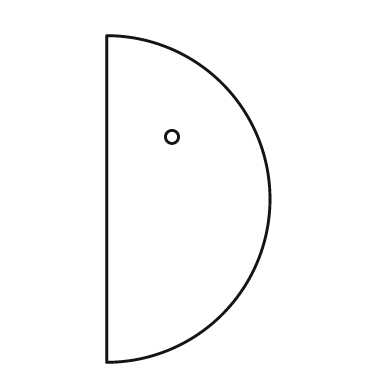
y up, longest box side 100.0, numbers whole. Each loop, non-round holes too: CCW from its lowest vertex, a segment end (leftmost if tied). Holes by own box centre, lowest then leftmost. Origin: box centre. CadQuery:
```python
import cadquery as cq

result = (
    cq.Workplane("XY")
    .moveTo(-25.0, -50.0)
    .threePointArc((25.0, 0.0), (-25.0, 50.0))
    .close()
    .moveTo(-5.0, 19.0)
    .circle(2.0)
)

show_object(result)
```